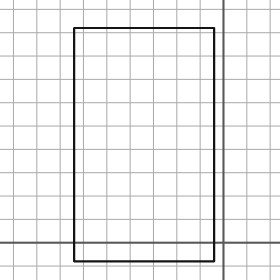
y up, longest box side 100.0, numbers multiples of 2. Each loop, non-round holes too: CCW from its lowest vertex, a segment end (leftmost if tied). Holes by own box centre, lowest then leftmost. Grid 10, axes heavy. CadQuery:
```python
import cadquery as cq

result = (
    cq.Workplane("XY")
    .moveTo(-64.0, -8.0)
    .lineTo(-4.0, -8.0)
    .lineTo(-4.0, 92.0)
    .lineTo(-64.0, 92.0)
    .close()
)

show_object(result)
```